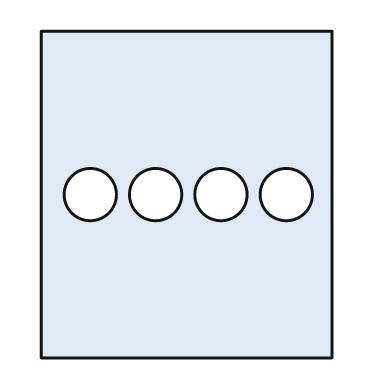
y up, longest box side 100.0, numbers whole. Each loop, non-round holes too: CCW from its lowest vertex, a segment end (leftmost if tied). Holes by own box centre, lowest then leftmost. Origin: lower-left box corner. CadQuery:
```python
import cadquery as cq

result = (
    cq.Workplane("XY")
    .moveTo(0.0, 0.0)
    .lineTo(89.0, 0.0)
    .lineTo(89.0, 100.0)
    .lineTo(0.0, 100.0)
    .close()
    .moveTo(15.0, 50.0)
    .circle(8.0)
    .moveTo(35.0, 50.0)
    .circle(8.0)
    .moveTo(55.0, 50.0)
    .circle(8.0)
    .moveTo(75.0, 50.0)
    .circle(8.0)
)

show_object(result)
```